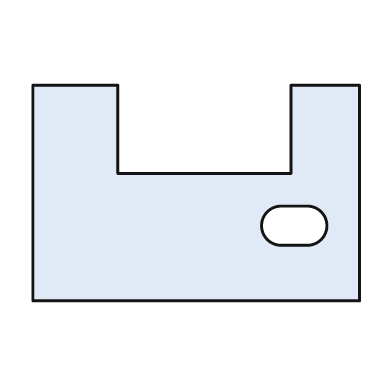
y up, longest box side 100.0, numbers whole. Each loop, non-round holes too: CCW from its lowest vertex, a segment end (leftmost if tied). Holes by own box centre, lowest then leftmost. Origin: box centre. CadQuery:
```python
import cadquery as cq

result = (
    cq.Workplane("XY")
    .moveTo(-50.0, -33.0)
    .lineTo(50.0, -33.0)
    .lineTo(50.0, 33.0)
    .lineTo(29.0, 33.0)
    .lineTo(29.0, 6.0)
    .lineTo(-24.0, 6.0)
    .lineTo(-24.0, 33.0)
    .lineTo(-50.0, 33.0)
    .close()
    .moveTo(26.0, -16.0)
    .lineTo(34.0, -16.0)
    .threePointArc((40.0, -10.0), (34.0, -4.0))
    .lineTo(26.0, -4.0)
    .threePointArc((20.0, -10.0), (26.0, -16.0))
    .close()
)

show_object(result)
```